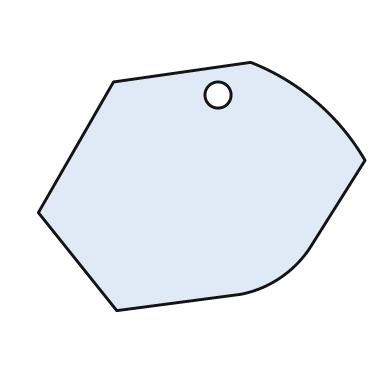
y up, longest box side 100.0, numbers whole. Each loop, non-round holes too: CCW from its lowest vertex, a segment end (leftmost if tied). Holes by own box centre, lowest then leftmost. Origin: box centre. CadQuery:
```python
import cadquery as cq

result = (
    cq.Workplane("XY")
    .moveTo(-26.0, -38.0)
    .lineTo(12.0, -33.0)
    .threePointArc((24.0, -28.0), (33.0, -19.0))
    .lineTo(50.0, 8.0)
    .threePointArc((35.0, 26.0), (15.0, 38.0))
    .lineTo(-27.0, 32.0)
    .lineTo(-50.0, -8.0)
    .close()
    .moveTo(5.0, 28.0)
    .circle(4.0)
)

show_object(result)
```